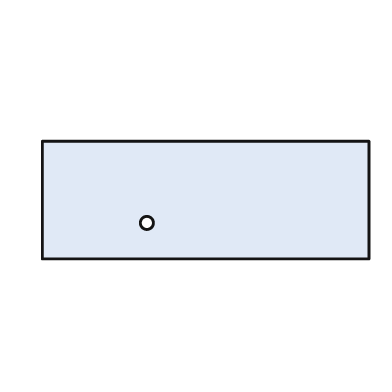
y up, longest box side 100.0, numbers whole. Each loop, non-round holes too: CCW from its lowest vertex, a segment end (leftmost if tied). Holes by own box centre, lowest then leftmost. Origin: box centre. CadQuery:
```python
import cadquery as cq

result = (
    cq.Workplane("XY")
    .moveTo(-50.0, -18.0)
    .lineTo(50.0, -18.0)
    .lineTo(50.0, 18.0)
    .lineTo(-50.0, 18.0)
    .close()
    .moveTo(-18.0, -7.0)
    .circle(2.0)
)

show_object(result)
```